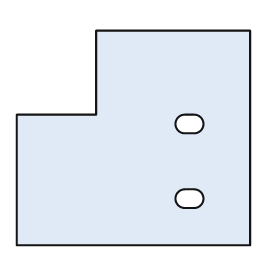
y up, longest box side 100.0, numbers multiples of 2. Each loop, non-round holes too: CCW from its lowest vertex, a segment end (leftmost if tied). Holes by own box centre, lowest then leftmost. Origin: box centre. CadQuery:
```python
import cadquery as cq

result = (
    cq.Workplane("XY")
    .moveTo(-50.0, -46.0)
    .lineTo(50.0, -46.0)
    .lineTo(50.0, 46.0)
    .lineTo(-16.0, 46.0)
    .lineTo(-16.0, 10.0)
    .lineTo(-50.0, 10.0)
    .close()
    .moveTo(22.0, -30.0)
    .lineTo(26.0, -30.0)
    .threePointArc((30.0, -26.0), (26.0, -22.0))
    .lineTo(22.0, -22.0)
    .threePointArc((18.0, -26.0), (22.0, -30.0))
    .close()
    .moveTo(22.0, 2.0)
    .lineTo(26.0, 2.0)
    .threePointArc((30.0, 6.0), (26.0, 10.0))
    .lineTo(22.0, 10.0)
    .threePointArc((18.0, 6.0), (22.0, 2.0))
    .close()
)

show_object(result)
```